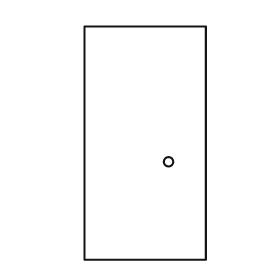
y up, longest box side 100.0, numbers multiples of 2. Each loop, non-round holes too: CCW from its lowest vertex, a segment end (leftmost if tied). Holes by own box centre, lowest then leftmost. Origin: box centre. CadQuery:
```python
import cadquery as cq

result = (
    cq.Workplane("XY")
    .moveTo(-26.0, -50.0)
    .lineTo(26.0, -50.0)
    .lineTo(26.0, 50.0)
    .lineTo(-26.0, 50.0)
    .close()
    .moveTo(10.0, -8.0)
    .circle(2.0)
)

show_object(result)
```